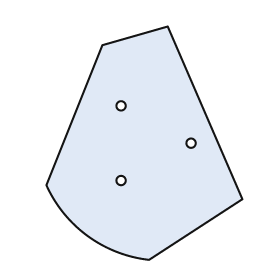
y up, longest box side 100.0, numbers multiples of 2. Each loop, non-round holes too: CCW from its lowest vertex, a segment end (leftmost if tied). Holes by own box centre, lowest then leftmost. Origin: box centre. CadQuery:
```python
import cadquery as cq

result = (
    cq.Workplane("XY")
    .moveTo(2.0, -50.0)
    .lineTo(42.0, -24.0)
    .lineTo(10.0, 50.0)
    .lineTo(-18.0, 42.0)
    .lineTo(-42.0, -18.0)
    .threePointArc((-24.0, -40.0), (2.0, -50.0))
    .close()
    .moveTo(-10.0, -16.0)
    .circle(2.0)
    .moveTo(20.0, 0.0)
    .circle(2.0)
    .moveTo(-10.0, 16.0)
    .circle(2.0)
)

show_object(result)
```